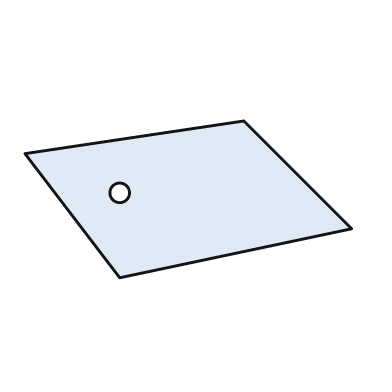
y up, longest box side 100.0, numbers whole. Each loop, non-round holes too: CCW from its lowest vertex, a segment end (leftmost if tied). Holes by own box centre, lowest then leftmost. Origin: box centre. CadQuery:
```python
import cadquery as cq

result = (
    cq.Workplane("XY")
    .moveTo(-21.0, -24.0)
    .lineTo(50.0, -9.0)
    .lineTo(17.0, 24.0)
    .lineTo(-50.0, 14.0)
    .close()
    .moveTo(-21.0, 2.0)
    .circle(3.0)
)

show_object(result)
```